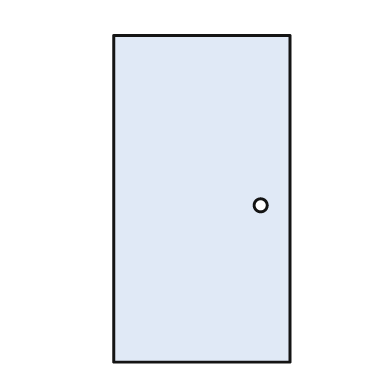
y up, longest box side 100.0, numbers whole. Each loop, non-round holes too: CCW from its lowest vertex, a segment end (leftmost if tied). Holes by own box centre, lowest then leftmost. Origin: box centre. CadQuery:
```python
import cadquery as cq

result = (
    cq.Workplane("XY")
    .moveTo(-27.0, -50.0)
    .lineTo(27.0, -50.0)
    .lineTo(27.0, 50.0)
    .lineTo(-27.0, 50.0)
    .close()
    .moveTo(18.0, -2.0)
    .circle(2.0)
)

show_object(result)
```